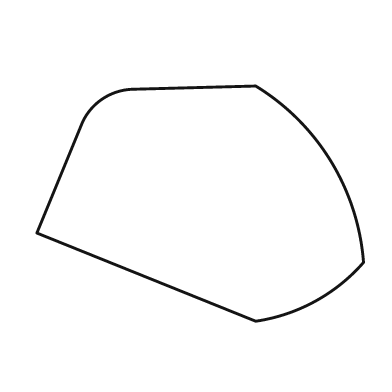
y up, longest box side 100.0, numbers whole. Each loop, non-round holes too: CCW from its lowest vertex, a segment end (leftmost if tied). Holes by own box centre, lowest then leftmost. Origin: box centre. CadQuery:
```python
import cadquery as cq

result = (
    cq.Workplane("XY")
    .moveTo(17.0, -36.0)
    .threePointArc((35.0, -30.0), (50.0, -18.0))
    .threePointArc((40.0, 13.0), (17.0, 36.0))
    .lineTo(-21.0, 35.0)
    .threePointArc((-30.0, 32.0), (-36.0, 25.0))
    .lineTo(-50.0, -9.0)
    .close()
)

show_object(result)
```